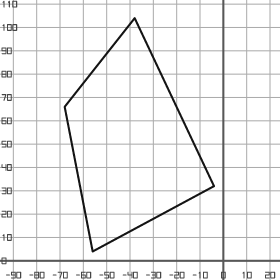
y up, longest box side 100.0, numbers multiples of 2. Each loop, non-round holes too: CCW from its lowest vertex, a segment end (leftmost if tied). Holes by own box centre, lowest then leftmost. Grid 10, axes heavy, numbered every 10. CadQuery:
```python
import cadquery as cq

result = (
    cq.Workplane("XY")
    .moveTo(-56.0, 4.0)
    .lineTo(-4.0, 32.0)
    .lineTo(-38.0, 104.0)
    .lineTo(-68.0, 66.0)
    .close()
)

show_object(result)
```